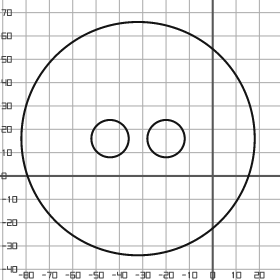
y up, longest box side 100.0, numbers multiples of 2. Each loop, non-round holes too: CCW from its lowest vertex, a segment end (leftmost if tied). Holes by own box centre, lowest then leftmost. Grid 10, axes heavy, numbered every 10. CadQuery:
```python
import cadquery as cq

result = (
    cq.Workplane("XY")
    .moveTo(-32.0, 16.0)
    .circle(50.0)
    .moveTo(-44.0, 16.0)
    .circle(8.0)
    .moveTo(-20.0, 16.0)
    .circle(8.0)
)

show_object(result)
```